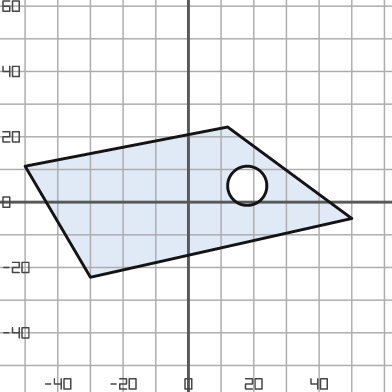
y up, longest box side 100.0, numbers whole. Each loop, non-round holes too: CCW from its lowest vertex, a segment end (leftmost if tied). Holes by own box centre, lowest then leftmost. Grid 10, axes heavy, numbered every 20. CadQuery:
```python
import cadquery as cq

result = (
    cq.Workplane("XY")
    .moveTo(-30.0, -23.0)
    .lineTo(50.0, -5.0)
    .lineTo(12.0, 23.0)
    .lineTo(-50.0, 11.0)
    .close()
    .moveTo(18.0, 5.0)
    .circle(6.0)
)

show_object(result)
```